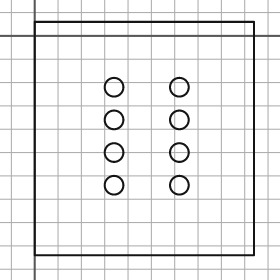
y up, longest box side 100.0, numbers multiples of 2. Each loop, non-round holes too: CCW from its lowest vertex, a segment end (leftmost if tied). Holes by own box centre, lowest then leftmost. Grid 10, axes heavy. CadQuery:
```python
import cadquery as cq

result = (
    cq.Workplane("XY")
    .moveTo(0.0, -94.0)
    .lineTo(94.0, -94.0)
    .lineTo(94.0, 6.0)
    .lineTo(0.0, 6.0)
    .close()
    .moveTo(34.0, -64.0)
    .circle(4.0)
    .moveTo(62.0, -64.0)
    .circle(4.0)
    .moveTo(34.0, -50.0)
    .circle(4.0)
    .moveTo(62.0, -50.0)
    .circle(4.0)
    .moveTo(34.0, -36.0)
    .circle(4.0)
    .moveTo(62.0, -36.0)
    .circle(4.0)
    .moveTo(34.0, -22.0)
    .circle(4.0)
    .moveTo(62.0, -22.0)
    .circle(4.0)
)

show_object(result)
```